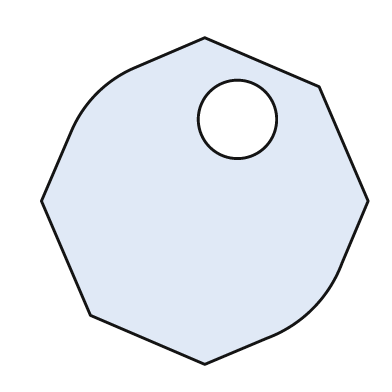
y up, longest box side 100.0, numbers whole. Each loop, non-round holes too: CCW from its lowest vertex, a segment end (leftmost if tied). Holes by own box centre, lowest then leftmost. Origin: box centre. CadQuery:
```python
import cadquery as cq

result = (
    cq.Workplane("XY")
    .moveTo(0.0, -50.0)
    .lineTo(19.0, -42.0)
    .threePointArc((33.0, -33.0), (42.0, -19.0))
    .lineTo(50.0, 0.0)
    .lineTo(35.0, 35.0)
    .lineTo(0.0, 50.0)
    .lineTo(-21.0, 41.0)
    .threePointArc((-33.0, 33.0), (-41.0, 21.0))
    .lineTo(-50.0, 0.0)
    .lineTo(-35.0, -35.0)
    .close()
    .moveTo(10.0, 25.0)
    .circle(12.0)
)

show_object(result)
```